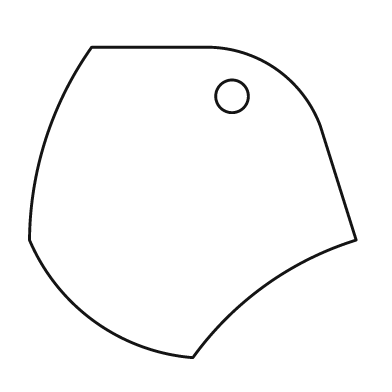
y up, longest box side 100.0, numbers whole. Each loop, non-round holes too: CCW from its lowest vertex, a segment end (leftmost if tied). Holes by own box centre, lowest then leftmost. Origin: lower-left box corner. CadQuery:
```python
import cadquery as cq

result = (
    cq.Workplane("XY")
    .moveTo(50.0, 0.0)
    .threePointArc((72.0, 22.0), (100.0, 36.0))
    .lineTo(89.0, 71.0)
    .threePointArc((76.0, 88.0), (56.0, 95.0))
    .lineTo(19.0, 95.0)
    .threePointArc((5.0, 67.0), (0.0, 36.0))
    .threePointArc((20.0, 11.0), (50.0, 0.0))
    .close()
    .moveTo(62.0, 80.0)
    .circle(5.0)
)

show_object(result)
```